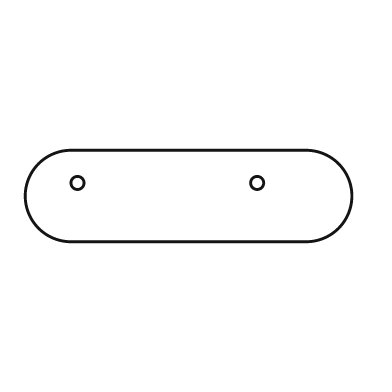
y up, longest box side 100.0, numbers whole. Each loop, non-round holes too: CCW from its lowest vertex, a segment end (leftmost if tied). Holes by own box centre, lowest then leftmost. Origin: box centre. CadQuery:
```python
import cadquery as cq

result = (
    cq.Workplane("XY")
    .moveTo(-36.0, -14.0)
    .lineTo(36.0, -14.0)
    .threePointArc((50.0, 0.0), (36.0, 14.0))
    .lineTo(-36.0, 14.0)
    .threePointArc((-50.0, 0.0), (-36.0, -14.0))
    .close()
    .moveTo(-34.0, 4.0)
    .circle(2.0)
    .moveTo(21.0, 4.0)
    .circle(2.0)
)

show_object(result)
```